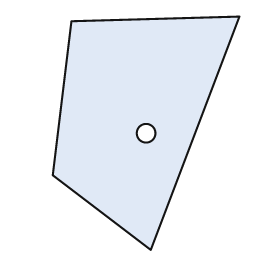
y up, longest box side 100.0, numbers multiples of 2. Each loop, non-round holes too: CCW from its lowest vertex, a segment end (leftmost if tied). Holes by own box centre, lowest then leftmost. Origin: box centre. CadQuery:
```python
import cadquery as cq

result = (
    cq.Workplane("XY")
    .moveTo(2.0, -50.0)
    .lineTo(40.0, 50.0)
    .lineTo(-32.0, 48.0)
    .lineTo(-40.0, -18.0)
    .close()
    .moveTo(0.0, 0.0)
    .circle(4.0)
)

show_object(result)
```